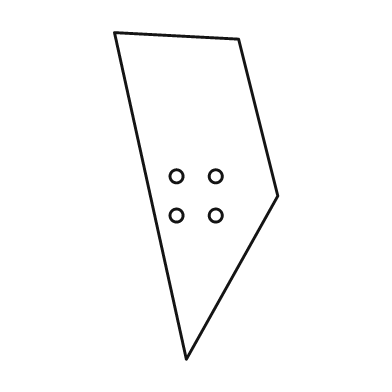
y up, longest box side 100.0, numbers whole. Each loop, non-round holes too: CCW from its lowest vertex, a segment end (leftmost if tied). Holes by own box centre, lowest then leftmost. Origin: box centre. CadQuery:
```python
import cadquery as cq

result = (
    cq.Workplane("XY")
    .moveTo(-3.0, -50.0)
    .lineTo(25.0, 0.0)
    .lineTo(13.0, 48.0)
    .lineTo(-25.0, 50.0)
    .close()
    .moveTo(-6.0, -6.0)
    .circle(2.0)
    .moveTo(6.0, -6.0)
    .circle(2.0)
    .moveTo(-6.0, 6.0)
    .circle(2.0)
    .moveTo(6.0, 6.0)
    .circle(2.0)
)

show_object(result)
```